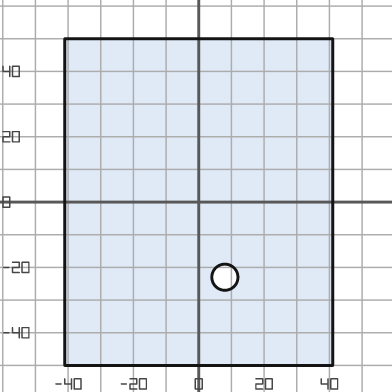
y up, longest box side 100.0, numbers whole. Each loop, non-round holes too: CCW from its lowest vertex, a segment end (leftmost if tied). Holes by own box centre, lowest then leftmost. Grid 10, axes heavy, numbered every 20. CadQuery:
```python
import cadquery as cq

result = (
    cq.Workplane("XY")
    .moveTo(-41.0, -50.0)
    .lineTo(41.0, -50.0)
    .lineTo(41.0, 50.0)
    .lineTo(-41.0, 50.0)
    .close()
    .moveTo(8.0, -23.0)
    .circle(4.0)
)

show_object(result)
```